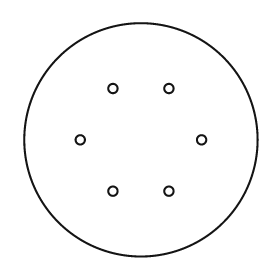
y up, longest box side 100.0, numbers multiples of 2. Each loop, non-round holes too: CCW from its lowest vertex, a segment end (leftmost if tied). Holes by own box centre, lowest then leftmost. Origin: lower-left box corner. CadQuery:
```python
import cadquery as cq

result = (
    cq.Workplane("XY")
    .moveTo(50.0, 50.0)
    .circle(50.0)
    .moveTo(38.0, 28.0)
    .circle(2.0)
    .moveTo(62.0, 28.0)
    .circle(2.0)
    .moveTo(24.0, 50.0)
    .circle(2.0)
    .moveTo(76.0, 50.0)
    .circle(2.0)
    .moveTo(38.0, 72.0)
    .circle(2.0)
    .moveTo(62.0, 72.0)
    .circle(2.0)
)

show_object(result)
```